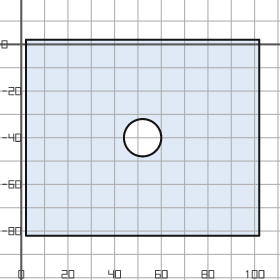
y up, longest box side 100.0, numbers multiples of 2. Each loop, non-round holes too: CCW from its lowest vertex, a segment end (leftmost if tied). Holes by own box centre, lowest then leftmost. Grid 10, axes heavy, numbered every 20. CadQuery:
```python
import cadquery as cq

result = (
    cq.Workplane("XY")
    .moveTo(2.0, -82.0)
    .lineTo(102.0, -82.0)
    .lineTo(102.0, 2.0)
    .lineTo(2.0, 2.0)
    .close()
    .moveTo(52.0, -40.0)
    .circle(8.0)
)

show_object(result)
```